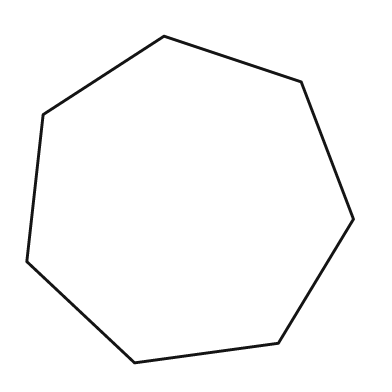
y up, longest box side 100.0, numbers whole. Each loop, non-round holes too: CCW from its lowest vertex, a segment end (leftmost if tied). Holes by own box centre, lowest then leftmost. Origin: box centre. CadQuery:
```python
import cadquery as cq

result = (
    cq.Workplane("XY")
    .moveTo(-17.0, -50.0)
    .lineTo(27.0, -44.0)
    .lineTo(50.0, -6.0)
    .lineTo(34.0, 36.0)
    .lineTo(-8.0, 50.0)
    .lineTo(-45.0, 26.0)
    .lineTo(-50.0, -19.0)
    .close()
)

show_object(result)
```